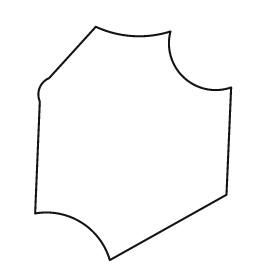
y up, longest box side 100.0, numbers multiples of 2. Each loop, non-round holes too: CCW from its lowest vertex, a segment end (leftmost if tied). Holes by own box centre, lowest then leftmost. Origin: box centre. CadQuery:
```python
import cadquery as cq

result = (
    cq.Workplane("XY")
    .moveTo(-10.0, -50.0)
    .lineTo(40.0, -22.0)
    .lineTo(42.0, 24.0)
    .threePointArc((22.0, 28.0), (16.0, 48.0))
    .threePointArc((0.0, 46.0), (-16.0, 50.0))
    .lineTo(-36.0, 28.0)
    .threePointArc((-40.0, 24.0), (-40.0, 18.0))
    .lineTo(-42.0, -30.0)
    .threePointArc((-22.0, -34.0), (-10.0, -50.0))
    .close()
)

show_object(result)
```